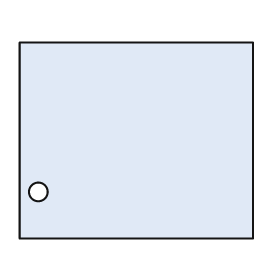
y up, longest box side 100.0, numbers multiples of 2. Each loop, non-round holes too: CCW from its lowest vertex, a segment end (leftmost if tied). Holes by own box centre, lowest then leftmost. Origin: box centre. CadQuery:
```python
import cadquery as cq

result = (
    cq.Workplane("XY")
    .moveTo(-50.0, -42.0)
    .lineTo(50.0, -42.0)
    .lineTo(50.0, 42.0)
    .lineTo(-50.0, 42.0)
    .close()
    .moveTo(-42.0, -22.0)
    .circle(4.0)
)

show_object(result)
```